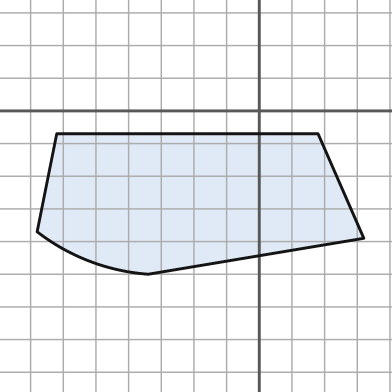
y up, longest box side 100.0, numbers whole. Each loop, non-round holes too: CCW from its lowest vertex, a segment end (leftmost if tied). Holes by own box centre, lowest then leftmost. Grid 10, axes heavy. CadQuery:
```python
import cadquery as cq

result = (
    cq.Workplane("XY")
    .moveTo(-34.0, -50.0)
    .lineTo(32.0, -39.0)
    .lineTo(18.0, -7.0)
    .lineTo(-62.0, -7.0)
    .lineTo(-68.0, -37.0)
    .threePointArc((-52.0, -46.0), (-34.0, -50.0))
    .close()
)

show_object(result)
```